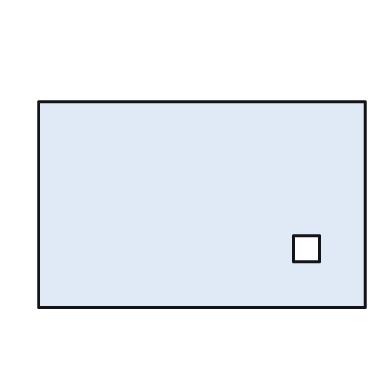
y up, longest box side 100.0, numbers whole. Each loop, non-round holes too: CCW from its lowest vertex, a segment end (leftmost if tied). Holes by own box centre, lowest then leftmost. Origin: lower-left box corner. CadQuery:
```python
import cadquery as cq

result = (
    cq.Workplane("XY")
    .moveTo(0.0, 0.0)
    .lineTo(100.0, 0.0)
    .lineTo(100.0, 63.0)
    .lineTo(0.0, 63.0)
    .close()
    .moveTo(78.0, 14.0)
    .lineTo(86.0, 14.0)
    .lineTo(86.0, 22.0)
    .lineTo(78.0, 22.0)
    .close()
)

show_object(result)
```